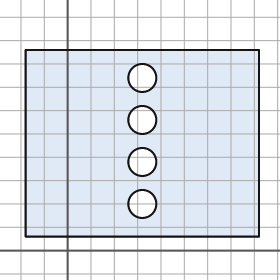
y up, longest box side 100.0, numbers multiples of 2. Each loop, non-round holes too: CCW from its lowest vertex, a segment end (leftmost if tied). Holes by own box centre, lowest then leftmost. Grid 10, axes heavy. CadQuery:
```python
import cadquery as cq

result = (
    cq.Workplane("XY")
    .moveTo(-18.0, 6.0)
    .lineTo(82.0, 6.0)
    .lineTo(82.0, 86.0)
    .lineTo(-18.0, 86.0)
    .close()
    .moveTo(32.0, 20.0)
    .circle(6.0)
    .moveTo(32.0, 38.0)
    .circle(6.0)
    .moveTo(32.0, 56.0)
    .circle(6.0)
    .moveTo(32.0, 74.0)
    .circle(6.0)
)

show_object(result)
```